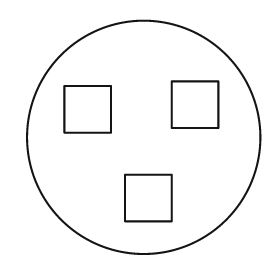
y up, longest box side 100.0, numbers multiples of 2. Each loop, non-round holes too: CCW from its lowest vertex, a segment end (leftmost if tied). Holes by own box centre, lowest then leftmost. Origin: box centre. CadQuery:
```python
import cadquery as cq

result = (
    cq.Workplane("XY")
    .moveTo(0.0, 0.0)
    .circle(50.0)
    .moveTo(-8.0, -36.0)
    .lineTo(12.0, -36.0)
    .lineTo(12.0, -16.0)
    .lineTo(-8.0, -16.0)
    .close()
    .moveTo(-34.0, 2.0)
    .lineTo(-14.0, 2.0)
    .lineTo(-14.0, 22.0)
    .lineTo(-34.0, 22.0)
    .close()
    .moveTo(12.0, 4.0)
    .lineTo(32.0, 4.0)
    .lineTo(32.0, 24.0)
    .lineTo(12.0, 24.0)
    .close()
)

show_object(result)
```